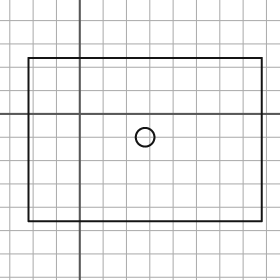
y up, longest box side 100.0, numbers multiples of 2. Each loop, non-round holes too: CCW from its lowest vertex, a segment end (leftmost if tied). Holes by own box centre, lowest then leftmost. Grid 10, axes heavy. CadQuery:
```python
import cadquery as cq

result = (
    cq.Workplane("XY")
    .moveTo(-22.0, -46.0)
    .lineTo(78.0, -46.0)
    .lineTo(78.0, 24.0)
    .lineTo(-22.0, 24.0)
    .close()
    .moveTo(28.0, -10.0)
    .circle(4.0)
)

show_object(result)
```